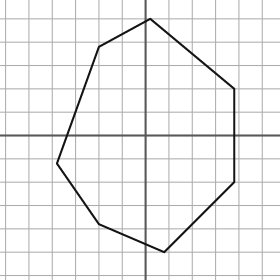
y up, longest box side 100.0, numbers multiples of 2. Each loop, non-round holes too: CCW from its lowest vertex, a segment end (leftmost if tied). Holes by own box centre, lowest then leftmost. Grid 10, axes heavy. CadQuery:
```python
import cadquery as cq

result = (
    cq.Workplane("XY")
    .moveTo(8.0, -50.0)
    .lineTo(38.0, -20.0)
    .lineTo(38.0, 20.0)
    .lineTo(2.0, 50.0)
    .lineTo(-20.0, 38.0)
    .lineTo(-38.0, -12.0)
    .lineTo(-20.0, -38.0)
    .close()
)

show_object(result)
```